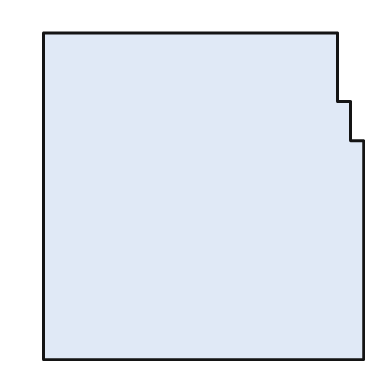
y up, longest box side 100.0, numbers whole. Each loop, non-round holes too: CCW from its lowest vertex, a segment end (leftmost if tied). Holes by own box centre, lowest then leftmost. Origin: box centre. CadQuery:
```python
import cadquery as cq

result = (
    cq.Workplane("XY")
    .moveTo(-49.0, -50.0)
    .lineTo(49.0, -50.0)
    .lineTo(49.0, 17.0)
    .lineTo(45.0, 17.0)
    .lineTo(45.0, 29.0)
    .lineTo(41.0, 29.0)
    .lineTo(41.0, 50.0)
    .lineTo(-49.0, 50.0)
    .close()
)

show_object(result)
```